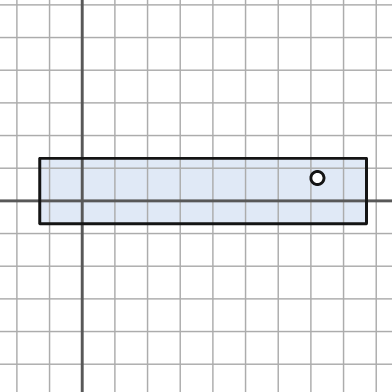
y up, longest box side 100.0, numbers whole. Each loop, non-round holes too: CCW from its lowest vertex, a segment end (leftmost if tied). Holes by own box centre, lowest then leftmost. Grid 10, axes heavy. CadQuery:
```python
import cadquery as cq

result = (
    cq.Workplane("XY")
    .moveTo(-13.0, -7.0)
    .lineTo(87.0, -7.0)
    .lineTo(87.0, 13.0)
    .lineTo(-13.0, 13.0)
    .close()
    .moveTo(72.0, 7.0)
    .circle(2.0)
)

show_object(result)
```